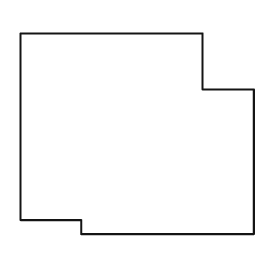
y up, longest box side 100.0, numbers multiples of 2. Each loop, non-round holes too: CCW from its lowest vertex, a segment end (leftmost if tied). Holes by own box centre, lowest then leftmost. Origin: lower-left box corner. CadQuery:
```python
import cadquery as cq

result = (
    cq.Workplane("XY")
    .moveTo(26.0, 0.0)
    .lineTo(100.0, 0.0)
    .lineTo(100.0, 62.0)
    .lineTo(78.0, 62.0)
    .lineTo(78.0, 86.0)
    .lineTo(0.0, 86.0)
    .lineTo(0.0, 6.0)
    .lineTo(26.0, 6.0)
    .close()
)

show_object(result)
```